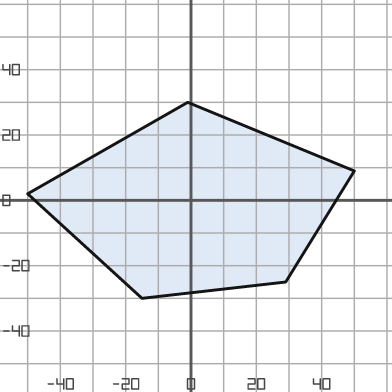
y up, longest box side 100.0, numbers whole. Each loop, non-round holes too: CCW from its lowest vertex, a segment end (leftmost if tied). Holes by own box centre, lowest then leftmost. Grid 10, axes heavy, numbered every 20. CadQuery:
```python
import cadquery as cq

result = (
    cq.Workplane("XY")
    .moveTo(-15.0, -30.0)
    .lineTo(29.0, -25.0)
    .lineTo(50.0, 9.0)
    .lineTo(-1.0, 30.0)
    .lineTo(-50.0, 2.0)
    .close()
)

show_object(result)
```